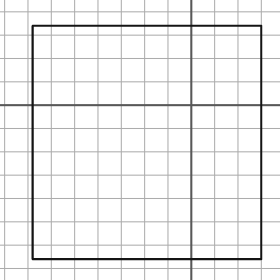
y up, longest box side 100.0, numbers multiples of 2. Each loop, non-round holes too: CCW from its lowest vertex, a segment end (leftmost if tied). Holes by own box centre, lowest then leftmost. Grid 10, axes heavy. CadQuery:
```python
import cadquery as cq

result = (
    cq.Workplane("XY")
    .moveTo(-68.0, -66.0)
    .lineTo(30.0, -66.0)
    .lineTo(30.0, 34.0)
    .lineTo(-68.0, 34.0)
    .close()
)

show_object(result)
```